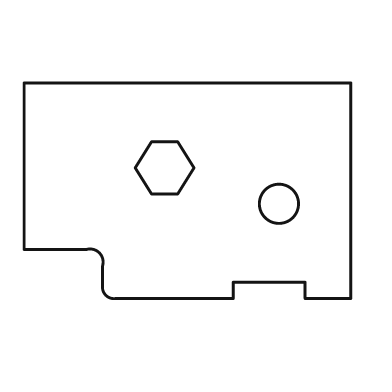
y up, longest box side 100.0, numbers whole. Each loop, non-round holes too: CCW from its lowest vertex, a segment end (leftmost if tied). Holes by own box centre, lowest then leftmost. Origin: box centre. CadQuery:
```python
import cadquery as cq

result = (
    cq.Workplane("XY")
    .moveTo(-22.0, -33.0)
    .lineTo(14.0, -33.0)
    .lineTo(14.0, -28.0)
    .lineTo(36.0, -28.0)
    .lineTo(36.0, -33.0)
    .lineTo(50.0, -33.0)
    .lineTo(50.0, 33.0)
    .lineTo(-50.0, 33.0)
    .lineTo(-50.0, -18.0)
    .lineTo(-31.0, -18.0)
    .threePointArc((-27.0, -19.0), (-26.0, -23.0))
    .lineTo(-26.0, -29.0)
    .threePointArc((-25.0, -32.0), (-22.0, -33.0))
    .close()
    .moveTo(28.0, -4.0)
    .circle(6.0)
    .moveTo(-11.0, -1.0)
    .lineTo(-3.0, -1.0)
    .lineTo(2.0, 7.0)
    .lineTo(-3.0, 15.0)
    .lineTo(-11.0, 15.0)
    .lineTo(-16.0, 7.0)
    .close()
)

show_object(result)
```